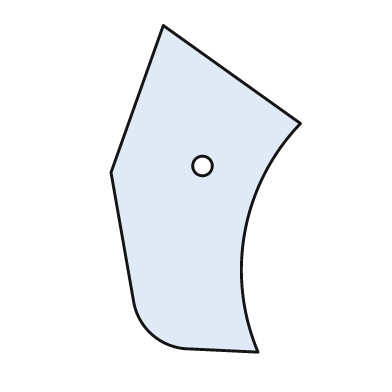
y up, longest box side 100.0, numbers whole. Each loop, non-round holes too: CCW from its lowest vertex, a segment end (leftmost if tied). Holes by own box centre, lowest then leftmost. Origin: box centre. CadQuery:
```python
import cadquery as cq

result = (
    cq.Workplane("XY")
    .moveTo(16.0, -50.0)
    .threePointArc((12.0, -13.0), (29.0, 20.0))
    .lineTo(-13.0, 50.0)
    .lineTo(-29.0, 5.0)
    .lineTo(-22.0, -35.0)
    .threePointArc((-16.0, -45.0), (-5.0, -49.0))
    .close()
    .moveTo(-1.0, 7.0)
    .circle(3.0)
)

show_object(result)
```